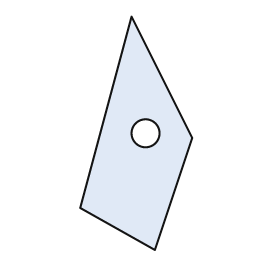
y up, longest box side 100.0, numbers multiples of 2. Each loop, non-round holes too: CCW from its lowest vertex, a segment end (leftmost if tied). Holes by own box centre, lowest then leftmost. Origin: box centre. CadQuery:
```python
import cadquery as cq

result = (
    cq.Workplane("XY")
    .moveTo(8.0, -50.0)
    .lineTo(24.0, -2.0)
    .lineTo(-2.0, 50.0)
    .lineTo(-24.0, -32.0)
    .close()
    .moveTo(4.0, 0.0)
    .circle(6.0)
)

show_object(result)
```